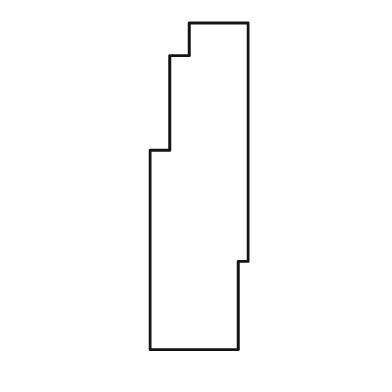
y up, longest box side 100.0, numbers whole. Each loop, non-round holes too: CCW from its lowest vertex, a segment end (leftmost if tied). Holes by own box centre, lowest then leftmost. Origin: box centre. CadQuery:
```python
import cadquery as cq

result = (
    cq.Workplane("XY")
    .moveTo(-15.0, -50.0)
    .lineTo(12.0, -50.0)
    .lineTo(12.0, -23.0)
    .lineTo(15.0, -23.0)
    .lineTo(15.0, 50.0)
    .lineTo(-3.0, 50.0)
    .lineTo(-3.0, 40.0)
    .lineTo(-9.0, 40.0)
    .lineTo(-9.0, 11.0)
    .lineTo(-15.0, 11.0)
    .close()
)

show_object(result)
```